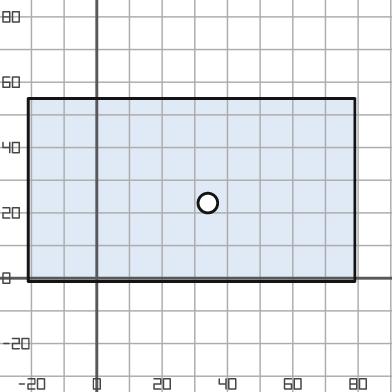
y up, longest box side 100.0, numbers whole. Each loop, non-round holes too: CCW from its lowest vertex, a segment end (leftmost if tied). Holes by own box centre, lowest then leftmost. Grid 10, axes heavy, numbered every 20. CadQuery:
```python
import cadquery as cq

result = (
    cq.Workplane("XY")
    .moveTo(-21.0, -1.0)
    .lineTo(79.0, -1.0)
    .lineTo(79.0, 55.0)
    .lineTo(-21.0, 55.0)
    .close()
    .moveTo(34.0, 23.0)
    .circle(3.0)
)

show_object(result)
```